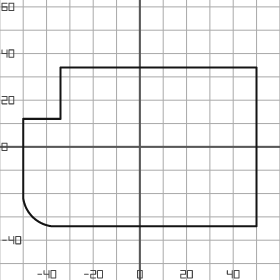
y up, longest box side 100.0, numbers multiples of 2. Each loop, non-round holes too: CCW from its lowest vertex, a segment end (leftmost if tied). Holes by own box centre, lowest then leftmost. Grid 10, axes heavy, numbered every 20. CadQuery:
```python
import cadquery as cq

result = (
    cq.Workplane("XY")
    .moveTo(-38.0, -34.0)
    .lineTo(50.0, -34.0)
    .lineTo(50.0, 34.0)
    .lineTo(-34.0, 34.0)
    .lineTo(-34.0, 12.0)
    .lineTo(-50.0, 12.0)
    .lineTo(-50.0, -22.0)
    .threePointArc((-46.0, -30.0), (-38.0, -34.0))
    .close()
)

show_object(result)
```